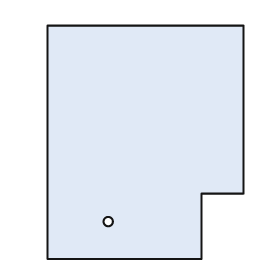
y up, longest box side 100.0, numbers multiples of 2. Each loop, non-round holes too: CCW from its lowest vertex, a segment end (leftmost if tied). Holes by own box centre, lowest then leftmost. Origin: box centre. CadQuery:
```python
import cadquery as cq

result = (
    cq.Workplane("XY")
    .moveTo(-42.0, -50.0)
    .lineTo(24.0, -50.0)
    .lineTo(24.0, -22.0)
    .lineTo(42.0, -22.0)
    .lineTo(42.0, 50.0)
    .lineTo(-42.0, 50.0)
    .close()
    .moveTo(-16.0, -34.0)
    .circle(2.0)
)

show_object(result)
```